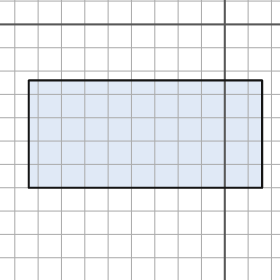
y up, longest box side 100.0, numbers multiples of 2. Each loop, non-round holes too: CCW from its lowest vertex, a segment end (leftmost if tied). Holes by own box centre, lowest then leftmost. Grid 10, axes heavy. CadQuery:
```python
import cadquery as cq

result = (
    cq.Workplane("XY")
    .moveTo(-84.0, -70.0)
    .lineTo(16.0, -70.0)
    .lineTo(16.0, -24.0)
    .lineTo(-84.0, -24.0)
    .close()
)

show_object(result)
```